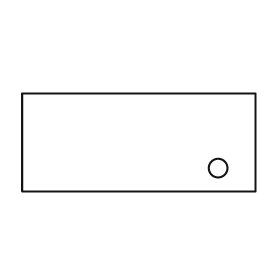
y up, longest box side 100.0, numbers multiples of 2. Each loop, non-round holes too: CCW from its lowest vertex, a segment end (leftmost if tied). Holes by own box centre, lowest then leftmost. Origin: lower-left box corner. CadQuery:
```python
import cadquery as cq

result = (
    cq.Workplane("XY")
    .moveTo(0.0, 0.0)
    .lineTo(100.0, 0.0)
    .lineTo(100.0, 42.0)
    .lineTo(0.0, 42.0)
    .close()
    .moveTo(84.0, 10.0)
    .circle(4.0)
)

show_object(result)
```